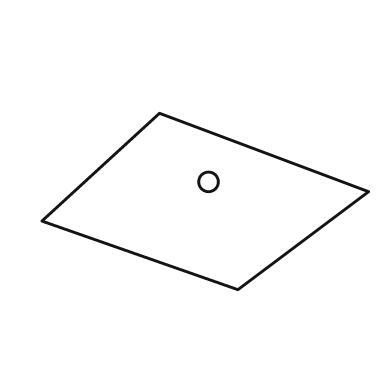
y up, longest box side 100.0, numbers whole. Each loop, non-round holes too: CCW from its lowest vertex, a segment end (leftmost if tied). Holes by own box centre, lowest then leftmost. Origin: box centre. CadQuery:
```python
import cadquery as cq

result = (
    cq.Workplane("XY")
    .moveTo(10.0, -27.0)
    .lineTo(50.0, 3.0)
    .lineTo(-14.0, 27.0)
    .lineTo(-50.0, -6.0)
    .close()
    .moveTo(1.0, 6.0)
    .circle(3.0)
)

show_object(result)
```